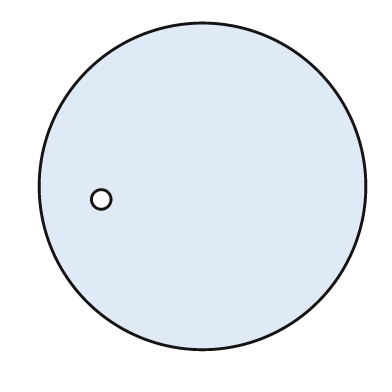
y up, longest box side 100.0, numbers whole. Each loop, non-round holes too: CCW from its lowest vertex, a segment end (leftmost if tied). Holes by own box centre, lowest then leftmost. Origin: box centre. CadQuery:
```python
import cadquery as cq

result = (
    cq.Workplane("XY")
    .moveTo(0.0, 0.0)
    .circle(50.0)
    .moveTo(-31.0, -4.0)
    .circle(3.0)
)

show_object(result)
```